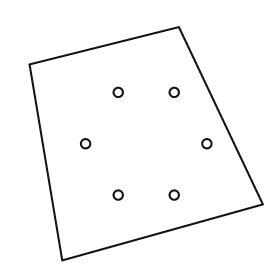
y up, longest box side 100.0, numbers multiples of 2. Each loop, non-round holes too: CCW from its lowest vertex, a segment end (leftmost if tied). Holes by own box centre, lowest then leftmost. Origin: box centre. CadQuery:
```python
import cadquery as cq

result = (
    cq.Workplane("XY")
    .moveTo(-36.0, -50.0)
    .lineTo(50.0, -26.0)
    .lineTo(14.0, 50.0)
    .lineTo(-50.0, 34.0)
    .close()
    .moveTo(-12.0, -22.0)
    .circle(2.0)
    .moveTo(12.0, -22.0)
    .circle(2.0)
    .moveTo(-26.0, 0.0)
    .circle(2.0)
    .moveTo(26.0, 0.0)
    .circle(2.0)
    .moveTo(-12.0, 22.0)
    .circle(2.0)
    .moveTo(12.0, 22.0)
    .circle(2.0)
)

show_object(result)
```